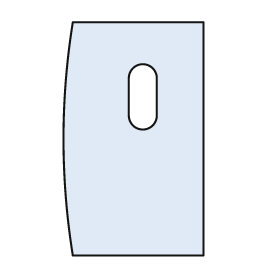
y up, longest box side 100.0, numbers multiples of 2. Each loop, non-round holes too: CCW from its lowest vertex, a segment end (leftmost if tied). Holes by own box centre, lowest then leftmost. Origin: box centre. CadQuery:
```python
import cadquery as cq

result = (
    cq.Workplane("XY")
    .moveTo(-26.0, -50.0)
    .lineTo(30.0, -50.0)
    .lineTo(30.0, 50.0)
    .lineTo(-26.0, 50.0)
    .threePointArc((-30.0, 0.0), (-26.0, -50.0))
    .close()
    .moveTo(-2.0, 10.0)
    .threePointArc((4.0, 4.0), (10.0, 10.0))
    .lineTo(10.0, 26.0)
    .threePointArc((4.0, 32.0), (-2.0, 26.0))
    .close()
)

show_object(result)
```